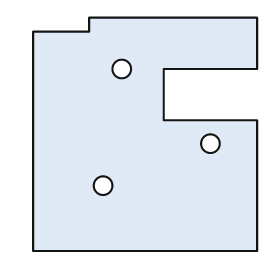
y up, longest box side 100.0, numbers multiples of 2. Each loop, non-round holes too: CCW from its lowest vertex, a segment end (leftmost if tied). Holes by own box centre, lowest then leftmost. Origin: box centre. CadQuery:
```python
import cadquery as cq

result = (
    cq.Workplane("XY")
    .moveTo(-48.0, -50.0)
    .lineTo(48.0, -50.0)
    .lineTo(48.0, 6.0)
    .lineTo(8.0, 6.0)
    .lineTo(8.0, 28.0)
    .lineTo(48.0, 28.0)
    .lineTo(48.0, 50.0)
    .lineTo(-24.0, 50.0)
    .lineTo(-24.0, 44.0)
    .lineTo(-48.0, 44.0)
    .close()
    .moveTo(-18.0, -22.0)
    .circle(4.0)
    .moveTo(28.0, -4.0)
    .circle(4.0)
    .moveTo(-10.0, 28.0)
    .circle(4.0)
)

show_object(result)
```